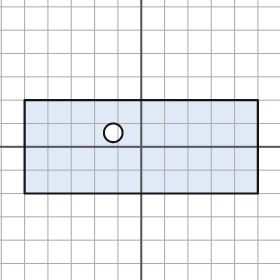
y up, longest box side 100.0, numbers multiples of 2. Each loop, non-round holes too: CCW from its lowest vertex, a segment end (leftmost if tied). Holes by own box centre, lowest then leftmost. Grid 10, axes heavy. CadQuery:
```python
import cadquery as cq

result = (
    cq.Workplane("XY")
    .moveTo(-50.0, -20.0)
    .lineTo(50.0, -20.0)
    .lineTo(50.0, 20.0)
    .lineTo(-50.0, 20.0)
    .close()
    .moveTo(-12.0, 6.0)
    .circle(4.0)
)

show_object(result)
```